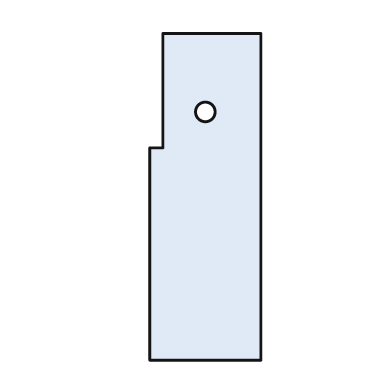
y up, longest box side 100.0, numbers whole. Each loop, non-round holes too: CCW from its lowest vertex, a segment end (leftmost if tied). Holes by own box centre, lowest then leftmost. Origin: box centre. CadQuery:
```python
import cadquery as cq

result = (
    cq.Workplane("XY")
    .moveTo(-17.0, -50.0)
    .lineTo(17.0, -50.0)
    .lineTo(17.0, 50.0)
    .lineTo(-13.0, 50.0)
    .lineTo(-13.0, 15.0)
    .lineTo(-17.0, 15.0)
    .close()
    .moveTo(0.0, 26.0)
    .circle(3.0)
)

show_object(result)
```